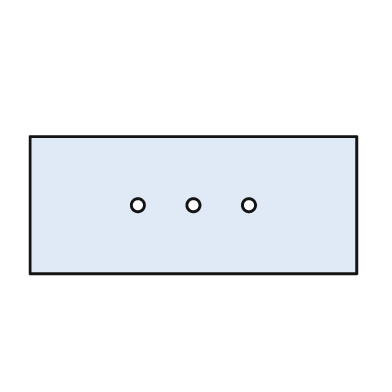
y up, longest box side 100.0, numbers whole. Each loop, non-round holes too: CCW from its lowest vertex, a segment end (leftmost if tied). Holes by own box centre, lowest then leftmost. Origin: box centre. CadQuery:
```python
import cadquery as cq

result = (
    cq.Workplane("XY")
    .moveTo(-50.0, -21.0)
    .lineTo(50.0, -21.0)
    .lineTo(50.0, 21.0)
    .lineTo(-50.0, 21.0)
    .close()
    .moveTo(-17.0, 0.0)
    .circle(2.0)
    .moveTo(0.0, 0.0)
    .circle(2.0)
    .moveTo(17.0, 0.0)
    .circle(2.0)
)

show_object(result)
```